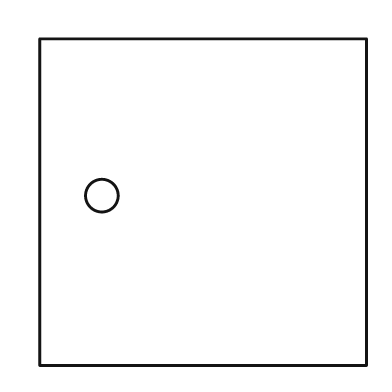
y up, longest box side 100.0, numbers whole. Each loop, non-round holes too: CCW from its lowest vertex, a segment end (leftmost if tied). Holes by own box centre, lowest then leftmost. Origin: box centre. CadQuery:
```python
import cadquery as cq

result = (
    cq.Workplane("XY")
    .moveTo(-50.0, -50.0)
    .lineTo(50.0, -50.0)
    .lineTo(50.0, 50.0)
    .lineTo(-50.0, 50.0)
    .close()
    .moveTo(-31.0, 2.0)
    .circle(5.0)
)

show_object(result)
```